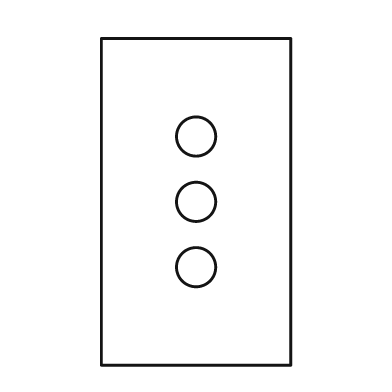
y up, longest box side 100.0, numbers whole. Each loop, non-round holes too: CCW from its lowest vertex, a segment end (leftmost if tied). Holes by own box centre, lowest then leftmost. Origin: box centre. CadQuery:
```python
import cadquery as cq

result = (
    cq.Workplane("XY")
    .moveTo(-29.0, -50.0)
    .lineTo(29.0, -50.0)
    .lineTo(29.0, 50.0)
    .lineTo(-29.0, 50.0)
    .close()
    .moveTo(0.0, -20.0)
    .circle(6.0)
    .moveTo(0.0, 0.0)
    .circle(6.0)
    .moveTo(0.0, 20.0)
    .circle(6.0)
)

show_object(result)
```